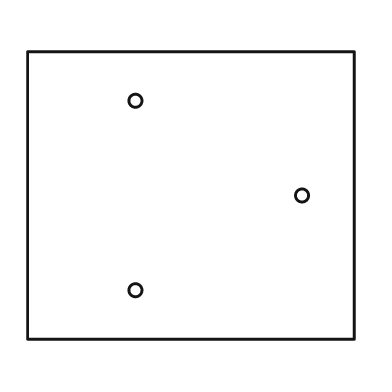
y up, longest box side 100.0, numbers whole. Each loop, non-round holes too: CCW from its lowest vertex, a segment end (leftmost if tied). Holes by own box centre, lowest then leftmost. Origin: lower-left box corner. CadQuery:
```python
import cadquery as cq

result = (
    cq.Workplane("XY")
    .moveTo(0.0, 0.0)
    .lineTo(100.0, 0.0)
    .lineTo(100.0, 88.0)
    .lineTo(0.0, 88.0)
    .close()
    .moveTo(33.0, 15.0)
    .circle(2.0)
    .moveTo(84.0, 44.0)
    .circle(2.0)
    .moveTo(33.0, 73.0)
    .circle(2.0)
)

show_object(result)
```